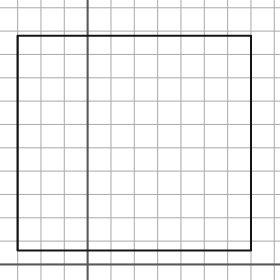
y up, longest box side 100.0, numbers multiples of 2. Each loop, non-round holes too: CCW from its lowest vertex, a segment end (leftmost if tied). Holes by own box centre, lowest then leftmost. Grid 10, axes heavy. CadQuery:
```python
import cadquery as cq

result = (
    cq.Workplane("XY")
    .moveTo(-30.0, 6.0)
    .lineTo(70.0, 6.0)
    .lineTo(70.0, 98.0)
    .lineTo(-30.0, 98.0)
    .close()
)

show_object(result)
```